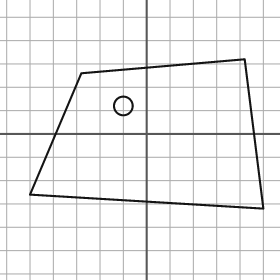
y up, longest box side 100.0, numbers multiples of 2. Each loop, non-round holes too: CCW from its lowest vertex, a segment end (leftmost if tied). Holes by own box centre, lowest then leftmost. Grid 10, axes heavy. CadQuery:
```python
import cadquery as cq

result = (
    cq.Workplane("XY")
    .moveTo(50.0, -32.0)
    .lineTo(42.0, 32.0)
    .lineTo(-28.0, 26.0)
    .lineTo(-50.0, -26.0)
    .close()
    .moveTo(-10.0, 12.0)
    .circle(4.0)
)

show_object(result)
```